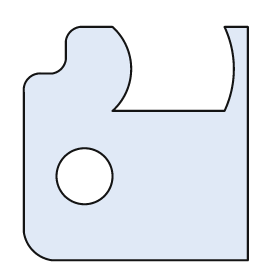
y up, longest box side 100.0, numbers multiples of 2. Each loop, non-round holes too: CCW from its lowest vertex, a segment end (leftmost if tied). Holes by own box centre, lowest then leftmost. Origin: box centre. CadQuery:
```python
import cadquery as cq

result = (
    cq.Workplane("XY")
    .moveTo(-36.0, -50.0)
    .lineTo(48.0, -50.0)
    .lineTo(48.0, 50.0)
    .lineTo(38.0, 50.0)
    .threePointArc((42.0, 32.0), (38.0, 14.0))
    .lineTo(-10.0, 14.0)
    .threePointArc((-2.0, 32.0), (-10.0, 50.0))
    .lineTo(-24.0, 50.0)
    .threePointArc((-28.0, 48.0), (-30.0, 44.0))
    .lineTo(-30.0, 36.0)
    .threePointArc((-32.0, 32.0), (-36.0, 30.0))
    .lineTo(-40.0, 30.0)
    .threePointArc((-46.0, 28.0), (-48.0, 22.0))
    .lineTo(-48.0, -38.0)
    .threePointArc((-44.0, -46.0), (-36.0, -50.0))
    .close()
    .moveTo(-22.0, -14.0)
    .circle(12.0)
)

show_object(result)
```